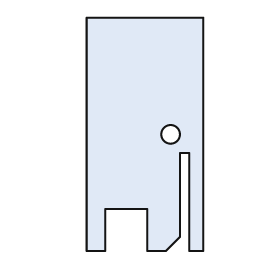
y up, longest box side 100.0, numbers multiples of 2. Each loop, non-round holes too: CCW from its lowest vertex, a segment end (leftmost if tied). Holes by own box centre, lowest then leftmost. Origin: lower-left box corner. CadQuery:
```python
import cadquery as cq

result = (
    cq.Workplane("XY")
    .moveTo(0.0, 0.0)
    .lineTo(8.0, 0.0)
    .lineTo(8.0, 18.0)
    .lineTo(26.0, 18.0)
    .lineTo(26.0, 0.0)
    .lineTo(34.0, 0.0)
    .lineTo(40.0, 6.0)
    .lineTo(40.0, 42.0)
    .lineTo(44.0, 42.0)
    .lineTo(44.0, 0.0)
    .lineTo(50.0, 0.0)
    .lineTo(50.0, 100.0)
    .lineTo(0.0, 100.0)
    .close()
    .moveTo(36.0, 50.0)
    .circle(4.0)
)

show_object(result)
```